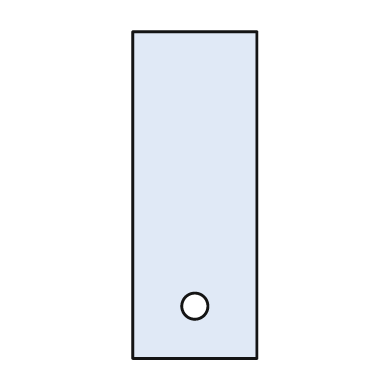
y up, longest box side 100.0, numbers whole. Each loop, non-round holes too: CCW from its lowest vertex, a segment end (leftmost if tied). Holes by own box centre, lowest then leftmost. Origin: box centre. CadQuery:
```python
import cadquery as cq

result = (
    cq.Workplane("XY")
    .moveTo(-19.0, -50.0)
    .lineTo(19.0, -50.0)
    .lineTo(19.0, 50.0)
    .lineTo(-19.0, 50.0)
    .close()
    .moveTo(0.0, -34.0)
    .circle(4.0)
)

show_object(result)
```